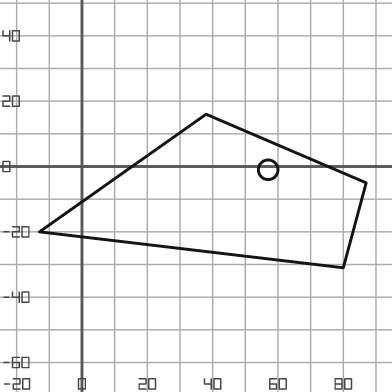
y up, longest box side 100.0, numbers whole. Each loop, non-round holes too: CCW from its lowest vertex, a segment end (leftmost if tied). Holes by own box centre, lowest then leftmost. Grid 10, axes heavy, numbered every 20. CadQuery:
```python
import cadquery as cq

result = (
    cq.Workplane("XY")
    .moveTo(80.0, -31.0)
    .lineTo(87.0, -5.0)
    .lineTo(38.0, 16.0)
    .lineTo(-13.0, -20.0)
    .close()
    .moveTo(57.0, -1.0)
    .circle(3.0)
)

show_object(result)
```